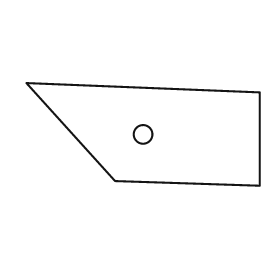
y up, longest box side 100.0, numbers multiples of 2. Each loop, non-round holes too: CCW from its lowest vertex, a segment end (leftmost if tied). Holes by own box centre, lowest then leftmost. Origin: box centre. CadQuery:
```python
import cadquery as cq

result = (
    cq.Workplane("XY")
    .moveTo(50.0, -22.0)
    .lineTo(50.0, 18.0)
    .lineTo(-50.0, 22.0)
    .lineTo(-12.0, -20.0)
    .close()
    .moveTo(0.0, 0.0)
    .circle(4.0)
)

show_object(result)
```